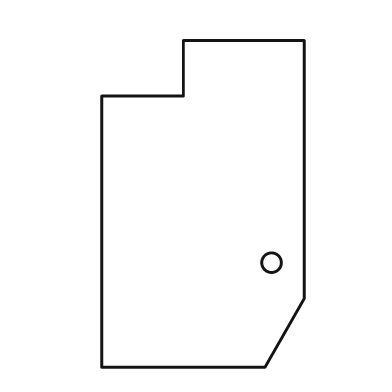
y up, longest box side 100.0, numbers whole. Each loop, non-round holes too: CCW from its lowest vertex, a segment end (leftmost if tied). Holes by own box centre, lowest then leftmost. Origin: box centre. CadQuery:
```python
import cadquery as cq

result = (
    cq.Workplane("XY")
    .moveTo(-31.0, -50.0)
    .lineTo(19.0, -50.0)
    .lineTo(31.0, -29.0)
    .lineTo(31.0, 50.0)
    .lineTo(-6.0, 50.0)
    .lineTo(-6.0, 33.0)
    .lineTo(-31.0, 33.0)
    .close()
    .moveTo(21.0, -18.0)
    .circle(3.0)
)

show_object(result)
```